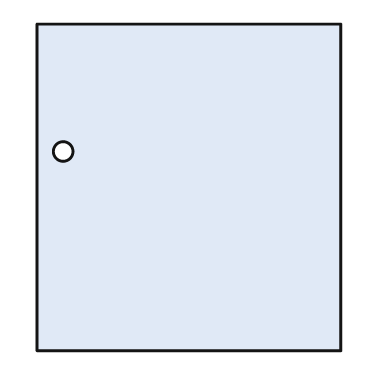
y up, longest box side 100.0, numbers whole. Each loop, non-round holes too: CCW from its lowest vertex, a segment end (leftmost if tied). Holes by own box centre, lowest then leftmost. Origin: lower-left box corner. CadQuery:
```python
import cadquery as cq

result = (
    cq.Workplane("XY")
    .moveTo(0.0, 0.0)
    .lineTo(93.0, 0.0)
    .lineTo(93.0, 100.0)
    .lineTo(0.0, 100.0)
    .close()
    .moveTo(8.0, 61.0)
    .circle(3.0)
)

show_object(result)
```